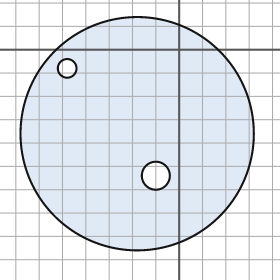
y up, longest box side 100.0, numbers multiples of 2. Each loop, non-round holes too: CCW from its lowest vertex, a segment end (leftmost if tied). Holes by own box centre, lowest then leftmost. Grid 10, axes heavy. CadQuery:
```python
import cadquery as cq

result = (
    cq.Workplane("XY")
    .moveTo(-18.0, -36.0)
    .circle(50.0)
    .moveTo(-10.0, -54.0)
    .circle(6.0)
    .moveTo(-48.0, -8.0)
    .circle(4.0)
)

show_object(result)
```